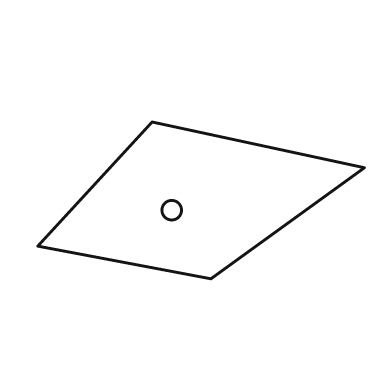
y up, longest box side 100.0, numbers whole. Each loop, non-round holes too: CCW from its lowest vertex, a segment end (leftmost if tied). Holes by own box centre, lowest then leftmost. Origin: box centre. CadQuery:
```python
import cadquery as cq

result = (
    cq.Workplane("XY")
    .moveTo(3.0, -24.0)
    .lineTo(50.0, 10.0)
    .lineTo(-15.0, 24.0)
    .lineTo(-50.0, -14.0)
    .close()
    .moveTo(-9.0, -3.0)
    .circle(3.0)
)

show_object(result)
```